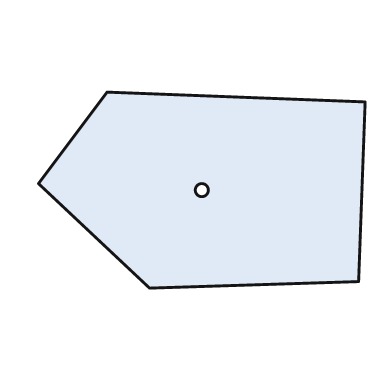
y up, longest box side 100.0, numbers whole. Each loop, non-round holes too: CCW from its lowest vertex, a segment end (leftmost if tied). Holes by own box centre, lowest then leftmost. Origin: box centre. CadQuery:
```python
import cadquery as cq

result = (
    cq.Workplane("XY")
    .moveTo(-16.0, -30.0)
    .lineTo(48.0, -28.0)
    .lineTo(50.0, 27.0)
    .lineTo(-29.0, 30.0)
    .lineTo(-50.0, 2.0)
    .close()
    .moveTo(0.0, 0.0)
    .circle(2.0)
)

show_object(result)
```